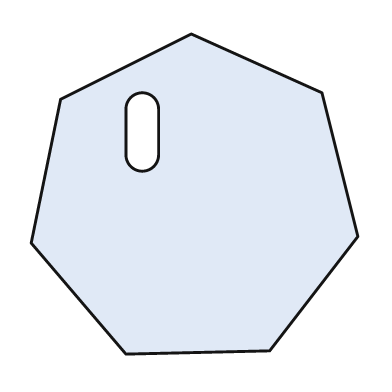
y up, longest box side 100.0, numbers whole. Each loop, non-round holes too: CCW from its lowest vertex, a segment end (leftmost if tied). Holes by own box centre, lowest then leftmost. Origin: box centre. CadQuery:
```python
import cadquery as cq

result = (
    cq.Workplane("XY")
    .moveTo(-21.0, -49.0)
    .lineTo(23.0, -48.0)
    .lineTo(50.0, -13.0)
    .lineTo(39.0, 31.0)
    .lineTo(-1.0, 49.0)
    .lineTo(-41.0, 29.0)
    .lineTo(-50.0, -15.0)
    .close()
    .moveTo(-21.0, 12.0)
    .threePointArc((-16.0, 7.0), (-11.0, 12.0))
    .lineTo(-11.0, 26.0)
    .threePointArc((-16.0, 31.0), (-21.0, 26.0))
    .close()
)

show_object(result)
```